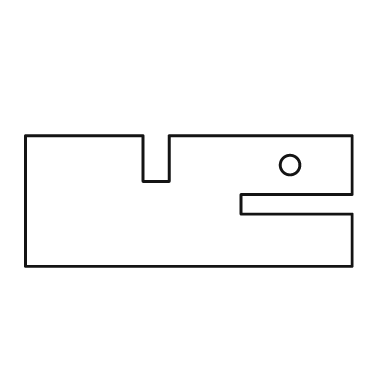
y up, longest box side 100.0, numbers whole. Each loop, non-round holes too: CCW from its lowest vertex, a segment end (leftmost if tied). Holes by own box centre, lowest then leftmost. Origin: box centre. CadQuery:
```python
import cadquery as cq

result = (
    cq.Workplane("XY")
    .moveTo(-50.0, -20.0)
    .lineTo(50.0, -20.0)
    .lineTo(50.0, -4.0)
    .lineTo(16.0, -4.0)
    .lineTo(16.0, 2.0)
    .lineTo(50.0, 2.0)
    .lineTo(50.0, 20.0)
    .lineTo(-6.0, 20.0)
    .lineTo(-6.0, 6.0)
    .lineTo(-14.0, 6.0)
    .lineTo(-14.0, 20.0)
    .lineTo(-50.0, 20.0)
    .close()
    .moveTo(31.0, 11.0)
    .circle(3.0)
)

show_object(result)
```